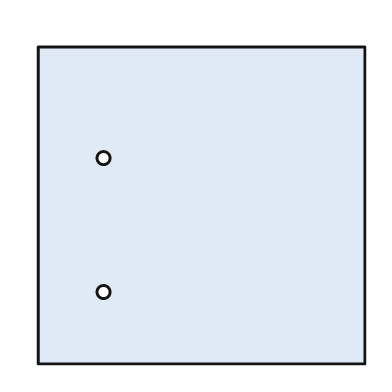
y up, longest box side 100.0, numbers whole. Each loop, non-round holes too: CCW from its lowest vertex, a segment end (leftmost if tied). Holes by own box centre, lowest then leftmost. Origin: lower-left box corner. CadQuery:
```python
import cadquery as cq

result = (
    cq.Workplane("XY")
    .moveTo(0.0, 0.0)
    .lineTo(100.0, 0.0)
    .lineTo(100.0, 97.0)
    .lineTo(0.0, 97.0)
    .close()
    .moveTo(20.0, 22.0)
    .circle(2.0)
    .moveTo(20.0, 63.0)
    .circle(2.0)
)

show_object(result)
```